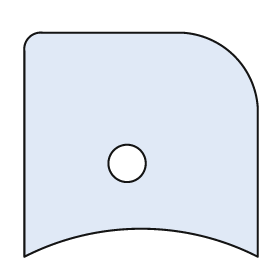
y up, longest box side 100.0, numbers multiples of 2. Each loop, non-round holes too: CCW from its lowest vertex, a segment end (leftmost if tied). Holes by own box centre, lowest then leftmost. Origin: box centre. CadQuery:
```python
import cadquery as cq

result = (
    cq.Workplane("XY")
    .moveTo(-50.0, -48.0)
    .threePointArc((0.0, -36.0), (50.0, -48.0))
    .lineTo(50.0, 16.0)
    .threePointArc((40.0, 38.0), (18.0, 48.0))
    .lineTo(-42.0, 48.0)
    .threePointArc((-48.0, 46.0), (-50.0, 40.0))
    .close()
    .moveTo(-6.0, -8.0)
    .circle(8.0)
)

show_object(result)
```